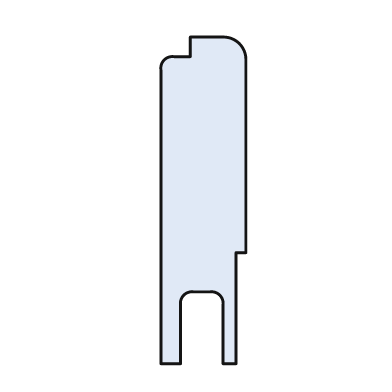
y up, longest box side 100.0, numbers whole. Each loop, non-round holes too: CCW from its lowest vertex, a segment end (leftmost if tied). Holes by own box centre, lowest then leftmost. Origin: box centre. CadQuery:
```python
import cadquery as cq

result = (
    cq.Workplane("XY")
    .moveTo(-13.0, -50.0)
    .lineTo(-7.0, -50.0)
    .lineTo(-7.0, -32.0)
    .threePointArc((-6.0, -29.0), (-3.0, -28.0))
    .lineTo(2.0, -28.0)
    .threePointArc((5.0, -29.0), (6.0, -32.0))
    .lineTo(6.0, -50.0)
    .lineTo(10.0, -50.0)
    .lineTo(10.0, -16.0)
    .lineTo(13.0, -16.0)
    .lineTo(13.0, 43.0)
    .threePointArc((11.0, 48.0), (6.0, 50.0))
    .lineTo(-4.0, 50.0)
    .lineTo(-4.0, 44.0)
    .lineTo(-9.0, 44.0)
    .threePointArc((-12.0, 43.0), (-13.0, 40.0))
    .close()
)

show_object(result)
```